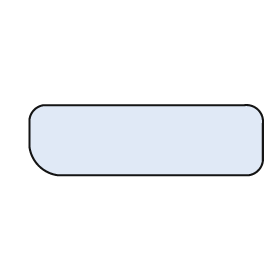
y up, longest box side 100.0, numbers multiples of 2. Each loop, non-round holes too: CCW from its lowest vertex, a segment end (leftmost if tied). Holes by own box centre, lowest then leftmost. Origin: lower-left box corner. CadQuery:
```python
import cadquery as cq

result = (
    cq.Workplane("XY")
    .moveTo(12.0, 0.0)
    .lineTo(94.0, 0.0)
    .threePointArc((98.0, 2.0), (100.0, 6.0))
    .lineTo(100.0, 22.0)
    .threePointArc((98.0, 28.0), (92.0, 30.0))
    .lineTo(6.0, 30.0)
    .threePointArc((2.0, 28.0), (0.0, 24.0))
    .lineTo(0.0, 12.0)
    .threePointArc((4.0, 4.0), (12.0, 0.0))
    .close()
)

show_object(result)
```